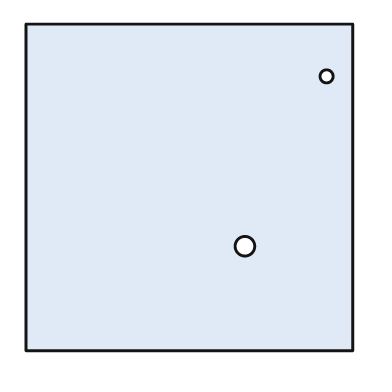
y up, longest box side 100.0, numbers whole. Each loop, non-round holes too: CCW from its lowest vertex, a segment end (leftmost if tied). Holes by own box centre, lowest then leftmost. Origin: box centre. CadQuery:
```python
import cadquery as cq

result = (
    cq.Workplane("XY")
    .moveTo(-50.0, -50.0)
    .lineTo(50.0, -50.0)
    .lineTo(50.0, 50.0)
    .lineTo(-50.0, 50.0)
    .close()
    .moveTo(17.0, -18.0)
    .circle(3.0)
    .moveTo(42.0, 34.0)
    .circle(2.0)
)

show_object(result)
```